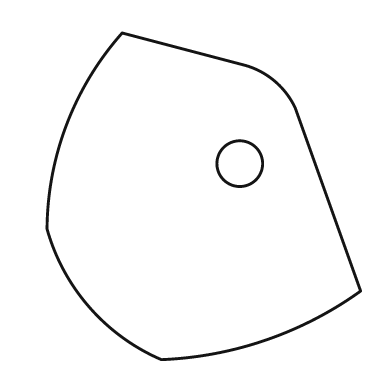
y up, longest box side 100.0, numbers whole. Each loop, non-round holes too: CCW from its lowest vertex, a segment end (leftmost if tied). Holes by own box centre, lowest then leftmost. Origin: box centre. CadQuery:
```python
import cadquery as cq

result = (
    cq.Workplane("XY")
    .moveTo(-13.0, -50.0)
    .threePointArc((19.0, -44.0), (48.0, -29.0))
    .lineTo(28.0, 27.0)
    .threePointArc((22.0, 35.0), (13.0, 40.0))
    .lineTo(-25.0, 50.0)
    .threePointArc((-42.0, 22.0), (-48.0, -10.0))
    .threePointArc((-35.0, -34.0), (-13.0, -50.0))
    .close()
    .moveTo(11.0, 10.0)
    .circle(7.0)
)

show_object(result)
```